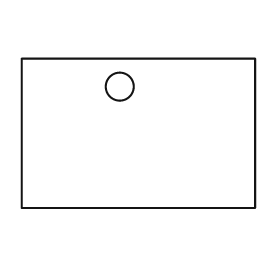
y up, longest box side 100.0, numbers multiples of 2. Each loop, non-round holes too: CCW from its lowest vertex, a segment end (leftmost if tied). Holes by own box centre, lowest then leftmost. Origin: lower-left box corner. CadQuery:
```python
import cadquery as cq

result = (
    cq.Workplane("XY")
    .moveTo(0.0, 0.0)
    .lineTo(100.0, 0.0)
    .lineTo(100.0, 64.0)
    .lineTo(0.0, 64.0)
    .close()
    .moveTo(42.0, 52.0)
    .circle(6.0)
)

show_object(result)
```